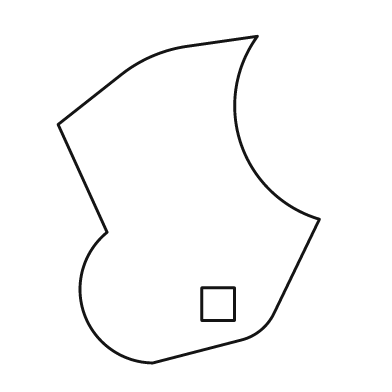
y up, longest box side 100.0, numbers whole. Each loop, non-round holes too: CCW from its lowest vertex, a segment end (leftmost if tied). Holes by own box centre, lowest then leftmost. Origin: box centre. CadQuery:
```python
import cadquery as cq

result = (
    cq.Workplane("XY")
    .moveTo(-11.0, -50.0)
    .lineTo(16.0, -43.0)
    .threePointArc((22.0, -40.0), (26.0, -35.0))
    .lineTo(40.0, -6.0)
    .threePointArc((16.0, 17.0), (21.0, 50.0))
    .lineTo(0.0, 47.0)
    .threePointArc((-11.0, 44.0), (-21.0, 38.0))
    .lineTo(-40.0, 23.0)
    .lineTo(-25.0, -10.0)
    .threePointArc((-32.0, -35.0), (-11.0, -50.0))
    .close()
    .moveTo(4.0, -37.0)
    .lineTo(14.0, -37.0)
    .lineTo(14.0, -27.0)
    .lineTo(4.0, -27.0)
    .close()
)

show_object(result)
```